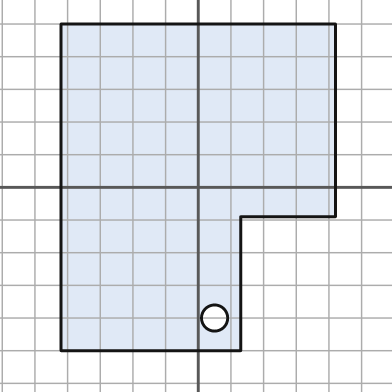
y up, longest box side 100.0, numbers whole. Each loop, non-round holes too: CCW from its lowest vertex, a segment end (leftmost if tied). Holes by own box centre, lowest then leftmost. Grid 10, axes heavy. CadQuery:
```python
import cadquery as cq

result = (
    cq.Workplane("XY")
    .moveTo(-42.0, -50.0)
    .lineTo(13.0, -50.0)
    .lineTo(13.0, -9.0)
    .lineTo(42.0, -9.0)
    .lineTo(42.0, 50.0)
    .lineTo(-42.0, 50.0)
    .close()
    .moveTo(5.0, -40.0)
    .circle(4.0)
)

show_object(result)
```